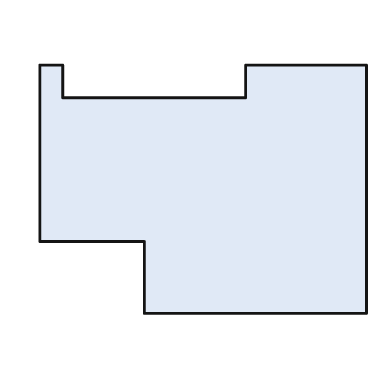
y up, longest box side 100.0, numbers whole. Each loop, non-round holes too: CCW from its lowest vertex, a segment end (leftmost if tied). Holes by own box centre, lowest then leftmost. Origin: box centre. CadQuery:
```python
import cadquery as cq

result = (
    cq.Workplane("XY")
    .moveTo(-18.0, -38.0)
    .lineTo(50.0, -38.0)
    .lineTo(50.0, 38.0)
    .lineTo(13.0, 38.0)
    .lineTo(13.0, 28.0)
    .lineTo(-43.0, 28.0)
    .lineTo(-43.0, 38.0)
    .lineTo(-50.0, 38.0)
    .lineTo(-50.0, -16.0)
    .lineTo(-18.0, -16.0)
    .close()
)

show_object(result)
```